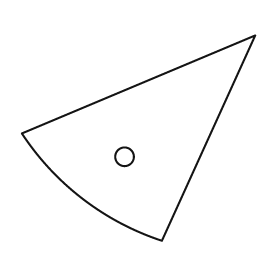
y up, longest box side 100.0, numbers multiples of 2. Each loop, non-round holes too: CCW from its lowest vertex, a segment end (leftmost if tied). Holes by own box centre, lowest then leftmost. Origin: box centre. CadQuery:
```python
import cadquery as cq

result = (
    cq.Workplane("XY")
    .moveTo(10.0, -44.0)
    .lineTo(50.0, 44.0)
    .lineTo(-50.0, 2.0)
    .threePointArc((-24.0, -26.0), (10.0, -44.0))
    .close()
    .moveTo(-6.0, -8.0)
    .circle(4.0)
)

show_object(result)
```